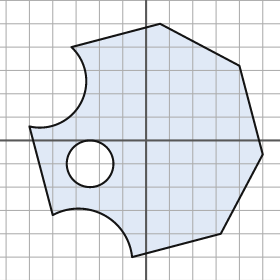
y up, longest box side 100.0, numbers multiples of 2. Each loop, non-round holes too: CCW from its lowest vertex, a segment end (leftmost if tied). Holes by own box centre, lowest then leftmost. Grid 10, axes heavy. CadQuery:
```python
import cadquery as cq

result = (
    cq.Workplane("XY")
    .moveTo(-6.0, -50.0)
    .lineTo(32.0, -40.0)
    .lineTo(50.0, -6.0)
    .lineTo(40.0, 32.0)
    .lineTo(6.0, 50.0)
    .lineTo(-32.0, 40.0)
    .threePointArc((-28.0, 16.0), (-50.0, 6.0))
    .lineTo(-40.0, -32.0)
    .threePointArc((-18.0, -32.0), (-6.0, -50.0))
    .close()
    .moveTo(-24.0, -10.0)
    .circle(10.0)
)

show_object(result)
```